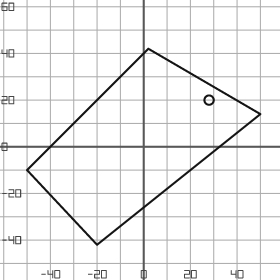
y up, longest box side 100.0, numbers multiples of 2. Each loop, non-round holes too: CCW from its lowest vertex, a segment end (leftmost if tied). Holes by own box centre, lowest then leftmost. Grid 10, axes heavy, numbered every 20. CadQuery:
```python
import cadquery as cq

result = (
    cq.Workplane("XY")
    .moveTo(-20.0, -42.0)
    .lineTo(50.0, 14.0)
    .lineTo(2.0, 42.0)
    .lineTo(-50.0, -10.0)
    .close()
    .moveTo(28.0, 20.0)
    .circle(2.0)
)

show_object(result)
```